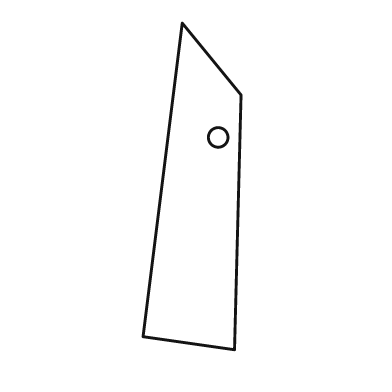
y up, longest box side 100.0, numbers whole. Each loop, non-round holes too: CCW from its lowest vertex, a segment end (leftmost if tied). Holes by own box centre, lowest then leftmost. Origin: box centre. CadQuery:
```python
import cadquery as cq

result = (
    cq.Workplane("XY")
    .moveTo(13.0, -50.0)
    .lineTo(15.0, 28.0)
    .lineTo(-3.0, 50.0)
    .lineTo(-15.0, -46.0)
    .close()
    .moveTo(8.0, 15.0)
    .circle(3.0)
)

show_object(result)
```